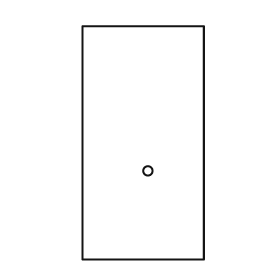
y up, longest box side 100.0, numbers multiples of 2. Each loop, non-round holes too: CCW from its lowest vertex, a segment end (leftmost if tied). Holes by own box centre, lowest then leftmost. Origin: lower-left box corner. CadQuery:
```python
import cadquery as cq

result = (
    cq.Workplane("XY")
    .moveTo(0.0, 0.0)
    .lineTo(52.0, 0.0)
    .lineTo(52.0, 100.0)
    .lineTo(0.0, 100.0)
    .close()
    .moveTo(28.0, 38.0)
    .circle(2.0)
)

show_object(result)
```